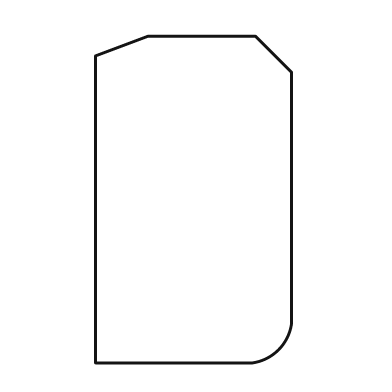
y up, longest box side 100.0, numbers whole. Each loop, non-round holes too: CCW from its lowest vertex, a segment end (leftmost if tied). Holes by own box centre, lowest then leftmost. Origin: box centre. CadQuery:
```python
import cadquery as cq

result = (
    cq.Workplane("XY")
    .moveTo(-30.0, -50.0)
    .lineTo(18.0, -50.0)
    .threePointArc((26.0, -46.0), (30.0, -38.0))
    .lineTo(30.0, 39.0)
    .lineTo(19.0, 50.0)
    .lineTo(-14.0, 50.0)
    .lineTo(-30.0, 44.0)
    .close()
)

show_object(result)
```